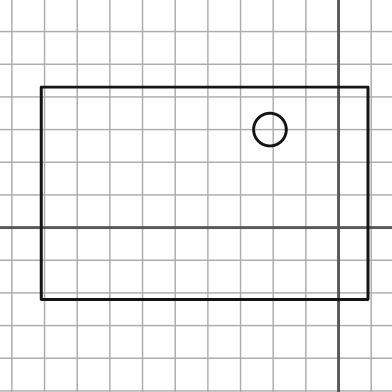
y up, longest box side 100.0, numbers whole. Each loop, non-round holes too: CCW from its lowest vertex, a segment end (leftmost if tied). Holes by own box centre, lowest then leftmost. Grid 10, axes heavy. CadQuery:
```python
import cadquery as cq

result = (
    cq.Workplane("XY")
    .moveTo(-91.0, -22.0)
    .lineTo(9.0, -22.0)
    .lineTo(9.0, 43.0)
    .lineTo(-91.0, 43.0)
    .close()
    .moveTo(-21.0, 30.0)
    .circle(5.0)
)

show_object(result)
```